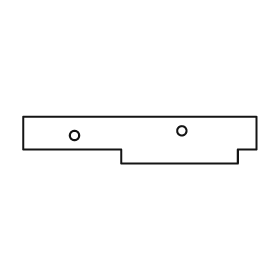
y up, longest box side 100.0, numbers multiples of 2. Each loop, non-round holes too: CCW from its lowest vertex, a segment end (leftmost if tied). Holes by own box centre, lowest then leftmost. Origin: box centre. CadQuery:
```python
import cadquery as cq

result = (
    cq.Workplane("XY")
    .moveTo(-8.0, -10.0)
    .lineTo(42.0, -10.0)
    .lineTo(42.0, -4.0)
    .lineTo(50.0, -4.0)
    .lineTo(50.0, 10.0)
    .lineTo(-50.0, 10.0)
    .lineTo(-50.0, -4.0)
    .lineTo(-8.0, -4.0)
    .close()
    .moveTo(-28.0, 2.0)
    .circle(2.0)
    .moveTo(18.0, 4.0)
    .circle(2.0)
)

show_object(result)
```